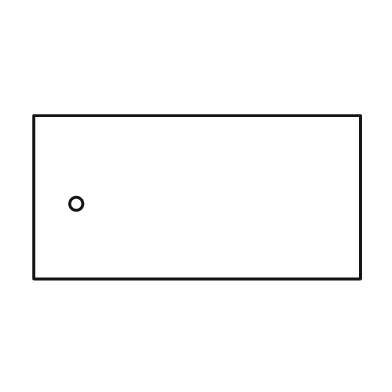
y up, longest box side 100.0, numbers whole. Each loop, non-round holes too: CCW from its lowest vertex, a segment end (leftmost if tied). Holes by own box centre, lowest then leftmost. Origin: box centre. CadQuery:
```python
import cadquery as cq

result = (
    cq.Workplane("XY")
    .moveTo(-50.0, -25.0)
    .lineTo(50.0, -25.0)
    .lineTo(50.0, 25.0)
    .lineTo(-50.0, 25.0)
    .close()
    .moveTo(-37.0, -2.0)
    .circle(2.0)
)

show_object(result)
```